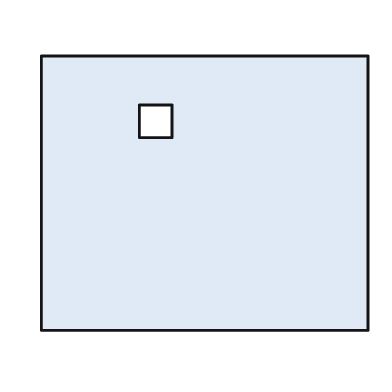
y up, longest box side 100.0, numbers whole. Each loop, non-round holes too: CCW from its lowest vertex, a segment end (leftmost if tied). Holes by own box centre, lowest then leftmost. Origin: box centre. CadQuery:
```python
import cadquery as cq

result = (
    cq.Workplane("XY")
    .moveTo(-50.0, -42.0)
    .lineTo(50.0, -42.0)
    .lineTo(50.0, 42.0)
    .lineTo(-50.0, 42.0)
    .close()
    .moveTo(-20.0, 17.0)
    .lineTo(-10.0, 17.0)
    .lineTo(-10.0, 27.0)
    .lineTo(-20.0, 27.0)
    .close()
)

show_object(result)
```